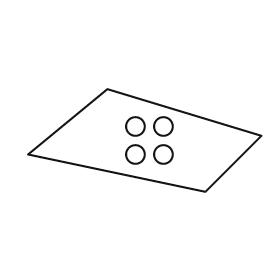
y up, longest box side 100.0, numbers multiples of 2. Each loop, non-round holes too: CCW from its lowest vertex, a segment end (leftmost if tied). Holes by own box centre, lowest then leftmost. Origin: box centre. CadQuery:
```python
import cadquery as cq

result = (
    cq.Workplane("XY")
    .moveTo(26.0, -22.0)
    .lineTo(50.0, 2.0)
    .lineTo(-16.0, 22.0)
    .lineTo(-50.0, -6.0)
    .close()
    .moveTo(-4.0, -6.0)
    .circle(4.0)
    .moveTo(8.0, -6.0)
    .circle(4.0)
    .moveTo(-4.0, 6.0)
    .circle(4.0)
    .moveTo(8.0, 6.0)
    .circle(4.0)
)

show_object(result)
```